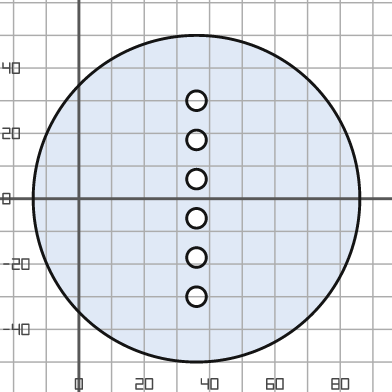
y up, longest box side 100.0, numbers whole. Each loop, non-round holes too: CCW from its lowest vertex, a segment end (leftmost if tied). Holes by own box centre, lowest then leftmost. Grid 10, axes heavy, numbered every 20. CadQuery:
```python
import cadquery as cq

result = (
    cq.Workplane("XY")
    .moveTo(36.0, 0.0)
    .circle(50.0)
    .moveTo(36.0, -30.0)
    .circle(3.0)
    .moveTo(36.0, -18.0)
    .circle(3.0)
    .moveTo(36.0, -6.0)
    .circle(3.0)
    .moveTo(36.0, 6.0)
    .circle(3.0)
    .moveTo(36.0, 18.0)
    .circle(3.0)
    .moveTo(36.0, 30.0)
    .circle(3.0)
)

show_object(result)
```